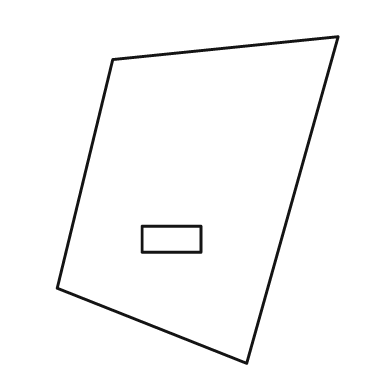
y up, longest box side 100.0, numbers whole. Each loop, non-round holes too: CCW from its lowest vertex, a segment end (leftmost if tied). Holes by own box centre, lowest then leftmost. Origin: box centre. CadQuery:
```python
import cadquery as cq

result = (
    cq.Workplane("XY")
    .moveTo(15.0, -50.0)
    .lineTo(43.0, 50.0)
    .lineTo(-26.0, 43.0)
    .lineTo(-43.0, -27.0)
    .close()
    .moveTo(-17.0, -16.0)
    .lineTo(1.0, -16.0)
    .lineTo(1.0, -8.0)
    .lineTo(-17.0, -8.0)
    .close()
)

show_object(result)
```